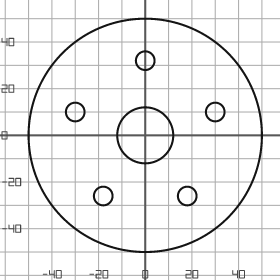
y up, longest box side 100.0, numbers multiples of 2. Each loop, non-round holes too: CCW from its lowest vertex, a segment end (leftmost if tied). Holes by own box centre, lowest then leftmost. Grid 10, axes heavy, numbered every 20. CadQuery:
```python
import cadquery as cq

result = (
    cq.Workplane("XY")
    .moveTo(0.0, 0.0)
    .circle(50.0)
    .moveTo(-18.0, -26.0)
    .circle(4.0)
    .moveTo(18.0, -26.0)
    .circle(4.0)
    .moveTo(0.0, 0.0)
    .circle(12.0)
    .moveTo(-30.0, 10.0)
    .circle(4.0)
    .moveTo(30.0, 10.0)
    .circle(4.0)
    .moveTo(0.0, 32.0)
    .circle(4.0)
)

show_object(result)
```